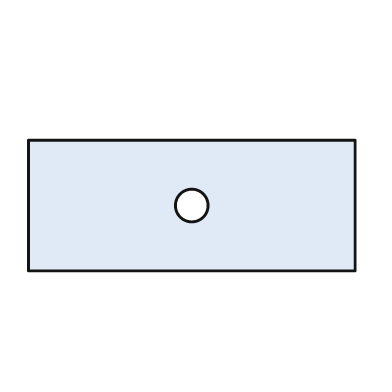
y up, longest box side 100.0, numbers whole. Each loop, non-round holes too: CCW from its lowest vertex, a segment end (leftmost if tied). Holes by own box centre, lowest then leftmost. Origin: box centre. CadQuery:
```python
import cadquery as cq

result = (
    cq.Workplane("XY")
    .moveTo(-50.0, -20.0)
    .lineTo(50.0, -20.0)
    .lineTo(50.0, 20.0)
    .lineTo(-50.0, 20.0)
    .close()
    .moveTo(0.0, 0.0)
    .circle(5.0)
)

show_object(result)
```